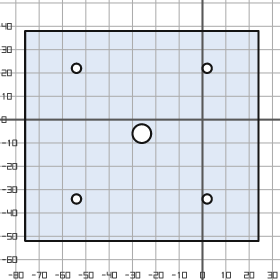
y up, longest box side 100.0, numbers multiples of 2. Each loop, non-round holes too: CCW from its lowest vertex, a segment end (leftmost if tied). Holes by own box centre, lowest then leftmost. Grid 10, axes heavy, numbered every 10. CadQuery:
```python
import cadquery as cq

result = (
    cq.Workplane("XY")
    .moveTo(-76.0, -52.0)
    .lineTo(24.0, -52.0)
    .lineTo(24.0, 38.0)
    .lineTo(-76.0, 38.0)
    .close()
    .moveTo(-54.0, -34.0)
    .circle(2.0)
    .moveTo(2.0, -34.0)
    .circle(2.0)
    .moveTo(-26.0, -6.0)
    .circle(4.0)
    .moveTo(-54.0, 22.0)
    .circle(2.0)
    .moveTo(2.0, 22.0)
    .circle(2.0)
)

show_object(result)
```